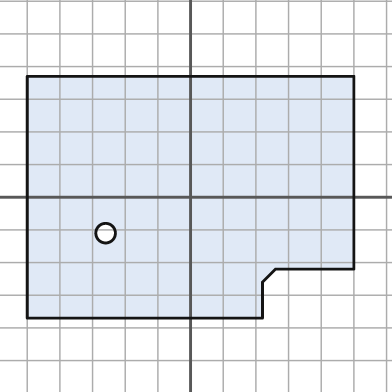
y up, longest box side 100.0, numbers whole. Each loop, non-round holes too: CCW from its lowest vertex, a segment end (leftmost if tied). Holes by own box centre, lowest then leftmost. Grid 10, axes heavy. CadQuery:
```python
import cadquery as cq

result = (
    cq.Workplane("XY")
    .moveTo(-50.0, -37.0)
    .lineTo(22.0, -37.0)
    .lineTo(22.0, -26.0)
    .lineTo(26.0, -22.0)
    .lineTo(50.0, -22.0)
    .lineTo(50.0, 37.0)
    .lineTo(-50.0, 37.0)
    .close()
    .moveTo(-26.0, -11.0)
    .circle(3.0)
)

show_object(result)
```